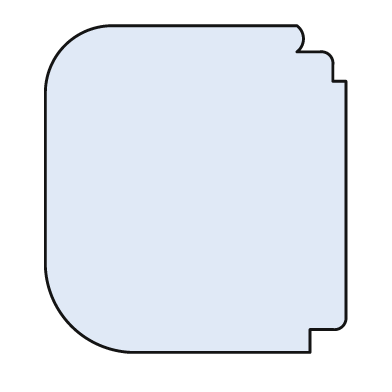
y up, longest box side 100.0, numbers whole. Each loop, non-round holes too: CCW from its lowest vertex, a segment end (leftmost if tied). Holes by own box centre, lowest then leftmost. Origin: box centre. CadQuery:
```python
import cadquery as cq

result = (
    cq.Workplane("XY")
    .moveTo(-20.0, -50.0)
    .lineTo(35.0, -50.0)
    .lineTo(35.0, -43.0)
    .lineTo(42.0, -43.0)
    .threePointArc((45.0, -42.0), (46.0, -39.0))
    .lineTo(46.0, 33.0)
    .lineTo(42.0, 33.0)
    .lineTo(42.0, 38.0)
    .threePointArc((41.0, 41.0), (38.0, 42.0))
    .lineTo(31.0, 42.0)
    .threePointArc((33.0, 46.0), (31.0, 50.0))
    .lineTo(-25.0, 50.0)
    .threePointArc((-40.0, 44.0), (-46.0, 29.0))
    .lineTo(-46.0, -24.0)
    .threePointArc((-38.0, -42.0), (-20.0, -50.0))
    .close()
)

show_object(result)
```